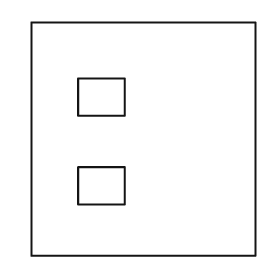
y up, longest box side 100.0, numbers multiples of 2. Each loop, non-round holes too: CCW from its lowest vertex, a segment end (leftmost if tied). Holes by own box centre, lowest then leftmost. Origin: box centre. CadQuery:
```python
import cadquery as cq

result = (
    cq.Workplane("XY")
    .moveTo(-48.0, -50.0)
    .lineTo(48.0, -50.0)
    .lineTo(48.0, 50.0)
    .lineTo(-48.0, 50.0)
    .close()
    .moveTo(-28.0, -28.0)
    .lineTo(-8.0, -28.0)
    .lineTo(-8.0, -12.0)
    .lineTo(-28.0, -12.0)
    .close()
    .moveTo(-28.0, 10.0)
    .lineTo(-8.0, 10.0)
    .lineTo(-8.0, 26.0)
    .lineTo(-28.0, 26.0)
    .close()
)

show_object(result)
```